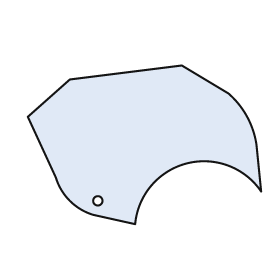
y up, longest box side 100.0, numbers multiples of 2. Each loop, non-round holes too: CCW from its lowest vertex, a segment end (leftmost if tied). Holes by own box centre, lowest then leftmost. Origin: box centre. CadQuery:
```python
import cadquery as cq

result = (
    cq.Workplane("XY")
    .moveTo(-4.0, -34.0)
    .threePointArc((18.0, -8.0), (50.0, -20.0))
    .lineTo(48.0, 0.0)
    .threePointArc((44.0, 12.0), (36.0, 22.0))
    .lineTo(16.0, 34.0)
    .lineTo(-32.0, 28.0)
    .lineTo(-50.0, 12.0)
    .lineTo(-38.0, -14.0)
    .threePointArc((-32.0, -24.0), (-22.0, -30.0))
    .close()
    .moveTo(-20.0, -24.0)
    .circle(2.0)
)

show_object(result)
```